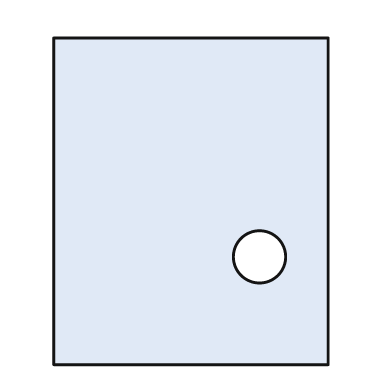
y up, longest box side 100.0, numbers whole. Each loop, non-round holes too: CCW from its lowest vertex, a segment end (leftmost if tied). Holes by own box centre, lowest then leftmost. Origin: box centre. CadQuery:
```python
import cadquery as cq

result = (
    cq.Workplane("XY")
    .moveTo(-42.0, -50.0)
    .lineTo(42.0, -50.0)
    .lineTo(42.0, 50.0)
    .lineTo(-42.0, 50.0)
    .close()
    .moveTo(21.0, -17.0)
    .circle(8.0)
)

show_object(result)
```